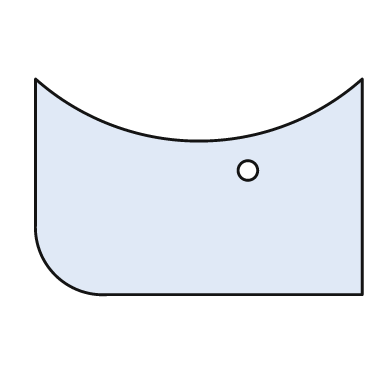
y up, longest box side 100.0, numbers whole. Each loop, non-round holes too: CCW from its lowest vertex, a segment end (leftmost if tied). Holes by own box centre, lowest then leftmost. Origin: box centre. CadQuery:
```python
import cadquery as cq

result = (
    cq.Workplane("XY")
    .moveTo(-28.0, -33.0)
    .lineTo(50.0, -33.0)
    .lineTo(50.0, 33.0)
    .threePointArc((0.0, 14.0), (-50.0, 33.0))
    .lineTo(-50.0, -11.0)
    .threePointArc((-44.0, -27.0), (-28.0, -33.0))
    .close()
    .moveTo(15.0, 5.0)
    .circle(3.0)
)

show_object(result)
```